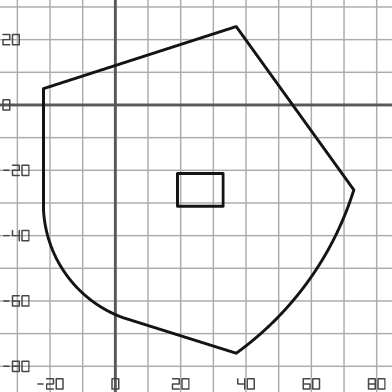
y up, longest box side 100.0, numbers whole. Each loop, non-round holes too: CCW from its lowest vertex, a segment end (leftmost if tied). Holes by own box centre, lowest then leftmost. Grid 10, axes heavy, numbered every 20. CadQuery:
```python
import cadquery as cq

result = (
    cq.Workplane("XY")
    .moveTo(37.0, -76.0)
    .threePointArc((59.0, -54.0), (73.0, -26.0))
    .lineTo(37.0, 24.0)
    .lineTo(-22.0, 5.0)
    .lineTo(-22.0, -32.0)
    .threePointArc((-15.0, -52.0), (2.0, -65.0))
    .close()
    .moveTo(19.0, -31.0)
    .lineTo(33.0, -31.0)
    .lineTo(33.0, -21.0)
    .lineTo(19.0, -21.0)
    .close()
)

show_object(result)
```